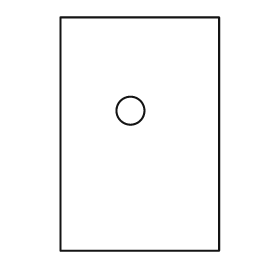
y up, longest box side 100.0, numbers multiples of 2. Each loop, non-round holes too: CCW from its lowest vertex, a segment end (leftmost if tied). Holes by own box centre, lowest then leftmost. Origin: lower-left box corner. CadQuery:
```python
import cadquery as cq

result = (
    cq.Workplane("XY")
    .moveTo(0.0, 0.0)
    .lineTo(68.0, 0.0)
    .lineTo(68.0, 100.0)
    .lineTo(0.0, 100.0)
    .close()
    .moveTo(30.0, 60.0)
    .circle(6.0)
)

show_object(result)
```